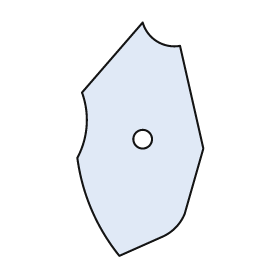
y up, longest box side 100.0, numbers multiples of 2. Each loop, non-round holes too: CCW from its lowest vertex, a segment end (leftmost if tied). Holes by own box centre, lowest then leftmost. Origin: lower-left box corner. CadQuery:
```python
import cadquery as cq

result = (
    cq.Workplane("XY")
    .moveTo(18.0, 0.0)
    .lineTo(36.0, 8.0)
    .threePointArc((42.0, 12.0), (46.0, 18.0))
    .lineTo(54.0, 46.0)
    .lineTo(44.0, 90.0)
    .threePointArc((34.0, 92.0), (28.0, 100.0))
    .lineTo(2.0, 70.0)
    .threePointArc((4.0, 56.0), (0.0, 42.0))
    .threePointArc((6.0, 20.0), (18.0, 0.0))
    .close()
    .moveTo(28.0, 50.0)
    .circle(4.0)
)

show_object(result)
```